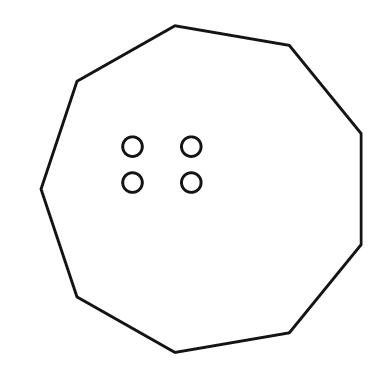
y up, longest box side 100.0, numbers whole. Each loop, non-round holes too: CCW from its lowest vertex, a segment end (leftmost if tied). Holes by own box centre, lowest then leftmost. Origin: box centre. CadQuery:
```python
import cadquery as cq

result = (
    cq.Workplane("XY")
    .moveTo(-8.0, -50.0)
    .lineTo(27.0, -44.0)
    .lineTo(49.0, -17.0)
    .lineTo(49.0, 17.0)
    .lineTo(27.0, 44.0)
    .lineTo(-8.0, 50.0)
    .lineTo(-38.0, 33.0)
    .lineTo(-49.0, 0.0)
    .lineTo(-38.0, -33.0)
    .close()
    .moveTo(-21.0, 2.0)
    .circle(3.0)
    .moveTo(-3.0, 2.0)
    .circle(3.0)
    .moveTo(-21.0, 13.0)
    .circle(3.0)
    .moveTo(-3.0, 13.0)
    .circle(3.0)
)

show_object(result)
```